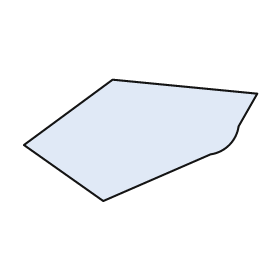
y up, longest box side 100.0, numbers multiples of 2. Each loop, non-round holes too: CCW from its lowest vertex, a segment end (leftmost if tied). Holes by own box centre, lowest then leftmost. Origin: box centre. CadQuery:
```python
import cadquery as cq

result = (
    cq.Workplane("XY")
    .moveTo(-16.0, -26.0)
    .lineTo(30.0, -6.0)
    .threePointArc((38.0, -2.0), (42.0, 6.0))
    .lineTo(50.0, 20.0)
    .lineTo(-12.0, 26.0)
    .lineTo(-50.0, -2.0)
    .close()
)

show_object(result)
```